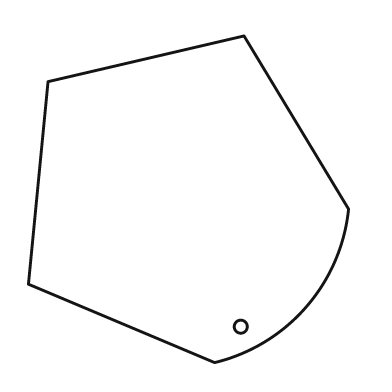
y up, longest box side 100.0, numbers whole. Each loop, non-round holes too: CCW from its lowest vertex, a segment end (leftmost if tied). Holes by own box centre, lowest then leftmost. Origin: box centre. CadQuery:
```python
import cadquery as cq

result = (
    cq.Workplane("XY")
    .moveTo(8.0, -50.0)
    .threePointArc((36.0, -33.0), (49.0, -3.0))
    .lineTo(17.0, 50.0)
    .lineTo(-43.0, 36.0)
    .lineTo(-49.0, -26.0)
    .close()
    .moveTo(16.0, -39.0)
    .circle(2.0)
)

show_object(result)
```